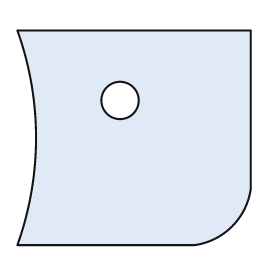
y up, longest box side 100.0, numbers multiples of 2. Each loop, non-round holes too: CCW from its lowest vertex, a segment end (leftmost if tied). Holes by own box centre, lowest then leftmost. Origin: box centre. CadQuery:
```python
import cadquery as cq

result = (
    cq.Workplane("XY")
    .moveTo(-50.0, -46.0)
    .lineTo(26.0, -46.0)
    .threePointArc((42.0, -38.0), (50.0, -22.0))
    .lineTo(50.0, 46.0)
    .lineTo(-50.0, 46.0)
    .threePointArc((-42.0, 0.0), (-50.0, -46.0))
    .close()
    .moveTo(-6.0, 16.0)
    .circle(8.0)
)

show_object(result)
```